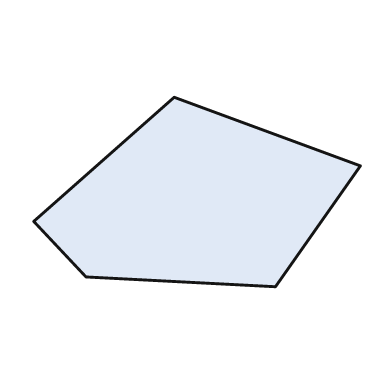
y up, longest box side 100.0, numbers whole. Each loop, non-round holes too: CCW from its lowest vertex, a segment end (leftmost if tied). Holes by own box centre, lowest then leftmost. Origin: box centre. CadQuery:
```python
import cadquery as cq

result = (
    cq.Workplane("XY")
    .moveTo(24.0, -29.0)
    .lineTo(50.0, 8.0)
    .lineTo(-7.0, 29.0)
    .lineTo(-50.0, -9.0)
    .lineTo(-34.0, -26.0)
    .close()
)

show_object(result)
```